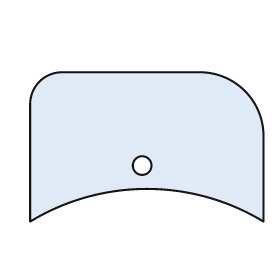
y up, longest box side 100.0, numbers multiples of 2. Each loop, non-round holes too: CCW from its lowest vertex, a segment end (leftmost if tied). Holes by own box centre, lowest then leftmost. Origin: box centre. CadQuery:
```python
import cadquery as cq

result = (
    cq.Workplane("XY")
    .moveTo(-50.0, -32.0)
    .threePointArc((0.0, -18.0), (50.0, -32.0))
    .lineTo(50.0, 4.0)
    .threePointArc((42.0, 24.0), (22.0, 32.0))
    .lineTo(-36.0, 32.0)
    .threePointArc((-46.0, 28.0), (-50.0, 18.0))
    .close()
    .moveTo(-2.0, -8.0)
    .circle(4.0)
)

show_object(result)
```